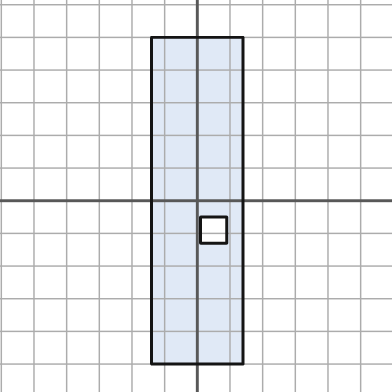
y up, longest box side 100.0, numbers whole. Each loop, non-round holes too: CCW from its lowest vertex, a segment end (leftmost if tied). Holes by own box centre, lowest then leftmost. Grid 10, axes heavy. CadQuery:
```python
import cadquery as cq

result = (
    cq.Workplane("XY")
    .moveTo(-14.0, -50.0)
    .lineTo(14.0, -50.0)
    .lineTo(14.0, 50.0)
    .lineTo(-14.0, 50.0)
    .close()
    .moveTo(1.0, -13.0)
    .lineTo(9.0, -13.0)
    .lineTo(9.0, -5.0)
    .lineTo(1.0, -5.0)
    .close()
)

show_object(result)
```